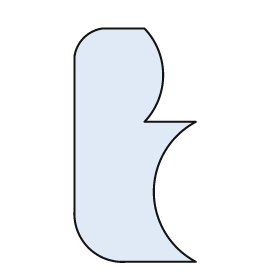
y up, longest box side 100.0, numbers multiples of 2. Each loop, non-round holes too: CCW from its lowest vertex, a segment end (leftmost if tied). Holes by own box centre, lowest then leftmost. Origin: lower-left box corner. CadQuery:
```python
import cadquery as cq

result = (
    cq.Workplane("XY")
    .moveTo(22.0, 0.0)
    .lineTo(52.0, 0.0)
    .threePointArc((34.0, 30.0), (52.0, 60.0))
    .lineTo(30.0, 60.0)
    .threePointArc((38.0, 80.0), (30.0, 100.0))
    .lineTo(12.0, 100.0)
    .threePointArc((4.0, 96.0), (0.0, 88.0))
    .lineTo(0.0, 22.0)
    .threePointArc((6.0, 6.0), (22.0, 0.0))
    .close()
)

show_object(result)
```